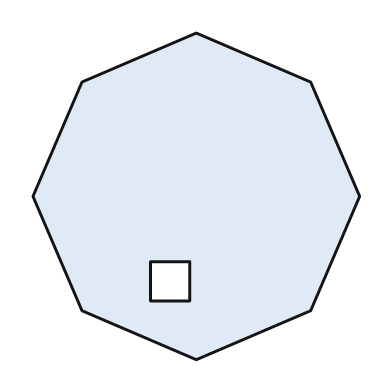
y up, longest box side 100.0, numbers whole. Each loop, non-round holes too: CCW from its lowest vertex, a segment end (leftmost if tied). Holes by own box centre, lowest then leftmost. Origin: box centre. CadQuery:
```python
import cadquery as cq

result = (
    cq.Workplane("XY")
    .moveTo(0.0, -50.0)
    .lineTo(35.0, -35.0)
    .lineTo(50.0, 0.0)
    .lineTo(35.0, 35.0)
    .lineTo(0.0, 50.0)
    .lineTo(-35.0, 35.0)
    .lineTo(-50.0, 0.0)
    .lineTo(-35.0, -35.0)
    .close()
    .moveTo(-14.0, -32.0)
    .lineTo(-2.0, -32.0)
    .lineTo(-2.0, -20.0)
    .lineTo(-14.0, -20.0)
    .close()
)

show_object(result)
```